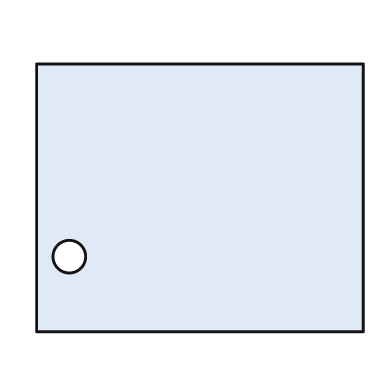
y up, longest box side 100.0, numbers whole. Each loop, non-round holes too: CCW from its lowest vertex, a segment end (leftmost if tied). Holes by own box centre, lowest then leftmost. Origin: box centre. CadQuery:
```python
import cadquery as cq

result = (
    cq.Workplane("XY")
    .moveTo(-50.0, -41.0)
    .lineTo(50.0, -41.0)
    .lineTo(50.0, 41.0)
    .lineTo(-50.0, 41.0)
    .close()
    .moveTo(-40.0, -18.0)
    .circle(5.0)
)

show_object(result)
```